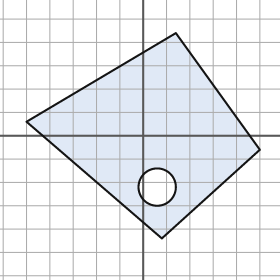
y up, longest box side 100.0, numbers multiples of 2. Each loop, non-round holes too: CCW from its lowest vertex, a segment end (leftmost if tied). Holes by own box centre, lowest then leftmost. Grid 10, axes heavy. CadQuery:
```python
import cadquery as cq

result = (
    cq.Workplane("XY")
    .moveTo(8.0, -44.0)
    .lineTo(50.0, -6.0)
    .lineTo(14.0, 44.0)
    .lineTo(-50.0, 6.0)
    .close()
    .moveTo(6.0, -22.0)
    .circle(8.0)
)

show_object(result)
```